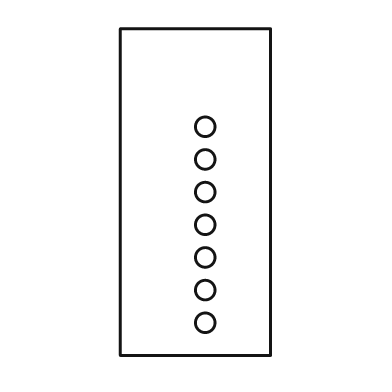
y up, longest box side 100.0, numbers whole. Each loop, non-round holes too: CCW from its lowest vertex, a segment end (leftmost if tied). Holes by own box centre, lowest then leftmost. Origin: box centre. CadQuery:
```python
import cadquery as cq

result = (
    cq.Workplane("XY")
    .moveTo(-23.0, -50.0)
    .lineTo(23.0, -50.0)
    .lineTo(23.0, 50.0)
    .lineTo(-23.0, 50.0)
    .close()
    .moveTo(3.0, -40.0)
    .circle(3.0)
    .moveTo(3.0, -30.0)
    .circle(3.0)
    .moveTo(3.0, -20.0)
    .circle(3.0)
    .moveTo(3.0, -10.0)
    .circle(3.0)
    .moveTo(3.0, 0.0)
    .circle(3.0)
    .moveTo(3.0, 10.0)
    .circle(3.0)
    .moveTo(3.0, 20.0)
    .circle(3.0)
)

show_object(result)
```